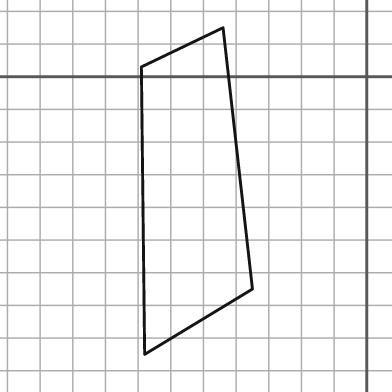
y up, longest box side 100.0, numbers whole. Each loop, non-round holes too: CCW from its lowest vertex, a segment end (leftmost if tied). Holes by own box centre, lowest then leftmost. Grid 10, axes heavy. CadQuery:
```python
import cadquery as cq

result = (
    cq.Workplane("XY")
    .moveTo(-68.0, -85.0)
    .lineTo(-35.0, -65.0)
    .lineTo(-44.0, 15.0)
    .lineTo(-69.0, 3.0)
    .close()
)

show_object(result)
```